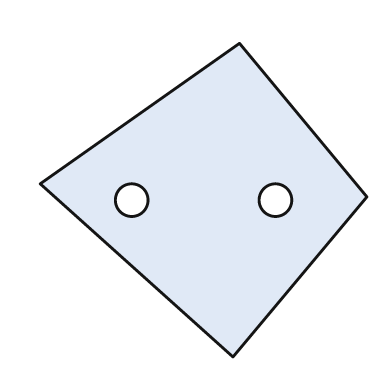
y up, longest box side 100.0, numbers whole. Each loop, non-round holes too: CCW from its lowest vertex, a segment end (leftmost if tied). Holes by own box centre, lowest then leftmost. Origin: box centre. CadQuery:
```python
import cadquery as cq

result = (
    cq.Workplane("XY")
    .moveTo(9.0, -48.0)
    .lineTo(50.0, 1.0)
    .lineTo(11.0, 48.0)
    .lineTo(-50.0, 5.0)
    .close()
    .moveTo(-22.0, 0.0)
    .circle(5.0)
    .moveTo(22.0, 0.0)
    .circle(5.0)
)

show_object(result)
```